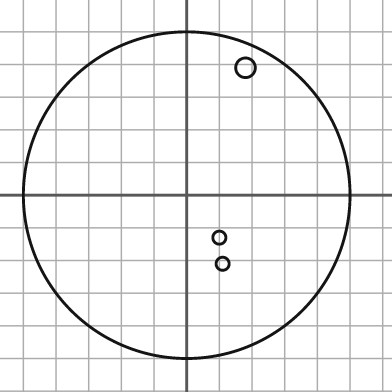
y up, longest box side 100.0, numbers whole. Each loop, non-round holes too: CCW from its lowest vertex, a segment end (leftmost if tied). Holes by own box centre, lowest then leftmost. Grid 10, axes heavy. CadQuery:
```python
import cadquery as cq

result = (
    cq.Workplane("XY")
    .moveTo(0.0, 0.0)
    .circle(50.0)
    .moveTo(11.0, -21.0)
    .circle(2.0)
    .moveTo(10.0, -13.0)
    .circle(2.0)
    .moveTo(18.0, 39.0)
    .circle(3.0)
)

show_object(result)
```